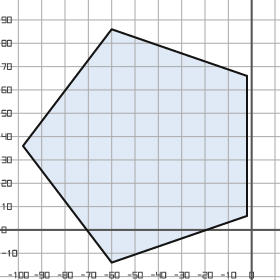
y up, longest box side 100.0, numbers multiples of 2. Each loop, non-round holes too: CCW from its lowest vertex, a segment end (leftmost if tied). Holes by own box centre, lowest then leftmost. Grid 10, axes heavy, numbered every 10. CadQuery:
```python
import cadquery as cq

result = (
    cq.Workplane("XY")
    .moveTo(-60.0, -14.0)
    .lineTo(-2.0, 6.0)
    .lineTo(-2.0, 66.0)
    .lineTo(-60.0, 86.0)
    .lineTo(-98.0, 36.0)
    .close()
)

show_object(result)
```